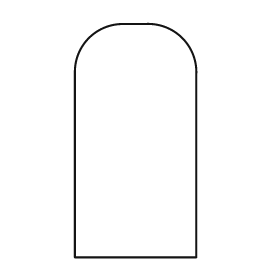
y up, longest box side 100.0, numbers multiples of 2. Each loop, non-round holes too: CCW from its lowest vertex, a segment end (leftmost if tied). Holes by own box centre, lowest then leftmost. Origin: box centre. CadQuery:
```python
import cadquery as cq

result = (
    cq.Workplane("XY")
    .moveTo(-26.0, -50.0)
    .lineTo(26.0, -50.0)
    .lineTo(26.0, 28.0)
    .threePointArc((20.0, 44.0), (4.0, 50.0))
    .lineTo(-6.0, 50.0)
    .threePointArc((-20.0, 44.0), (-26.0, 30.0))
    .close()
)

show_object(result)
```